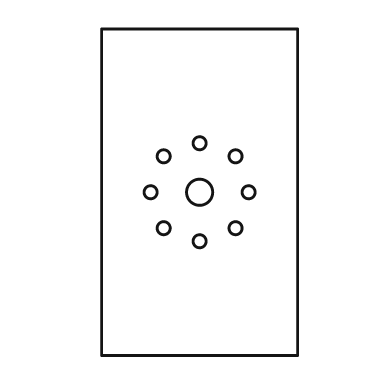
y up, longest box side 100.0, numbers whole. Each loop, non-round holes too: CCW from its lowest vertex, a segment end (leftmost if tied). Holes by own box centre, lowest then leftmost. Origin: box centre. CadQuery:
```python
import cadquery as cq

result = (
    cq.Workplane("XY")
    .moveTo(-30.0, -50.0)
    .lineTo(30.0, -50.0)
    .lineTo(30.0, 50.0)
    .lineTo(-30.0, 50.0)
    .close()
    .moveTo(0.0, -15.0)
    .circle(2.0)
    .moveTo(-11.0, -11.0)
    .circle(2.0)
    .moveTo(11.0, -11.0)
    .circle(2.0)
    .moveTo(-15.0, 0.0)
    .circle(2.0)
    .moveTo(0.0, 0.0)
    .circle(4.0)
    .moveTo(15.0, 0.0)
    .circle(2.0)
    .moveTo(-11.0, 11.0)
    .circle(2.0)
    .moveTo(11.0, 11.0)
    .circle(2.0)
    .moveTo(0.0, 15.0)
    .circle(2.0)
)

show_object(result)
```